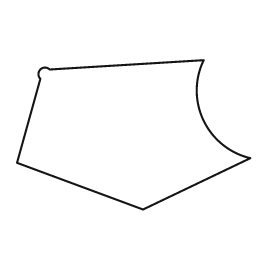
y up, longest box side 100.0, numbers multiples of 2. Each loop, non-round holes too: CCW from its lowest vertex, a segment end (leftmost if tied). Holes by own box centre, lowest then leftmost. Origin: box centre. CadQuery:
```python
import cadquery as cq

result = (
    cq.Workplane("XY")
    .moveTo(4.0, -32.0)
    .lineTo(50.0, -10.0)
    .threePointArc((30.0, 6.0), (30.0, 32.0))
    .lineTo(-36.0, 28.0)
    .threePointArc((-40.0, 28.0), (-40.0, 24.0))
    .lineTo(-50.0, -12.0)
    .close()
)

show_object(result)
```